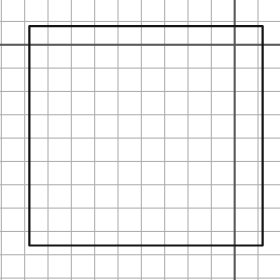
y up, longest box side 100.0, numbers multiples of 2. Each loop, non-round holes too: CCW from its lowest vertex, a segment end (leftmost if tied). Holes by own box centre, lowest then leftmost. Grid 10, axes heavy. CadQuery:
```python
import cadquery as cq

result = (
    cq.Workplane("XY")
    .moveTo(-88.0, -86.0)
    .lineTo(12.0, -86.0)
    .lineTo(12.0, 8.0)
    .lineTo(-88.0, 8.0)
    .close()
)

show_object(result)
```